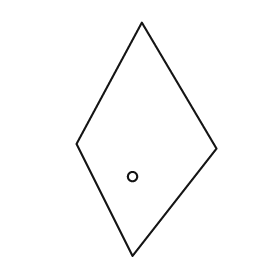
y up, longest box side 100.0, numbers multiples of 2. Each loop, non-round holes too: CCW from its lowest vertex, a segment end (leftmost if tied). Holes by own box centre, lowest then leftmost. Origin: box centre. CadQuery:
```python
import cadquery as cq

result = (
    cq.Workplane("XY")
    .moveTo(-6.0, -50.0)
    .lineTo(30.0, -4.0)
    .lineTo(-2.0, 50.0)
    .lineTo(-30.0, -2.0)
    .close()
    .moveTo(-6.0, -16.0)
    .circle(2.0)
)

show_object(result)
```